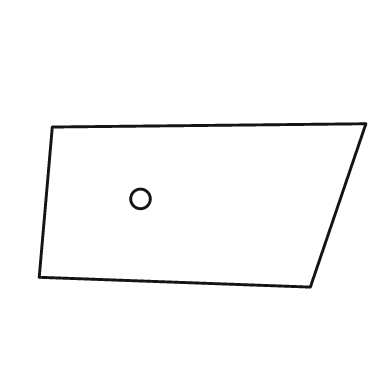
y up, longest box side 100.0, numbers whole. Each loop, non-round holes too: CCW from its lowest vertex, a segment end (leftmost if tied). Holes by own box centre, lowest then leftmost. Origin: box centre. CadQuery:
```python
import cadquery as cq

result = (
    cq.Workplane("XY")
    .moveTo(33.0, -25.0)
    .lineTo(50.0, 25.0)
    .lineTo(-46.0, 24.0)
    .lineTo(-50.0, -22.0)
    .close()
    .moveTo(-19.0, 2.0)
    .circle(3.0)
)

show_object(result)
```